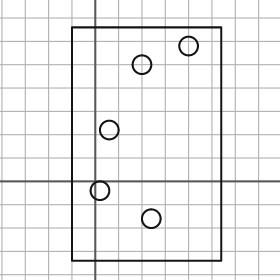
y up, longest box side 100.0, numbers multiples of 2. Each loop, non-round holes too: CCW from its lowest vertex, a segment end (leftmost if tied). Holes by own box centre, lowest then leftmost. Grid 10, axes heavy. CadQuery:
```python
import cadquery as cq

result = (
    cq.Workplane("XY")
    .moveTo(-10.0, -34.0)
    .lineTo(54.0, -34.0)
    .lineTo(54.0, 66.0)
    .lineTo(-10.0, 66.0)
    .close()
    .moveTo(24.0, -16.0)
    .circle(4.0)
    .moveTo(2.0, -4.0)
    .circle(4.0)
    .moveTo(6.0, 22.0)
    .circle(4.0)
    .moveTo(20.0, 50.0)
    .circle(4.0)
    .moveTo(40.0, 58.0)
    .circle(4.0)
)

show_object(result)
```